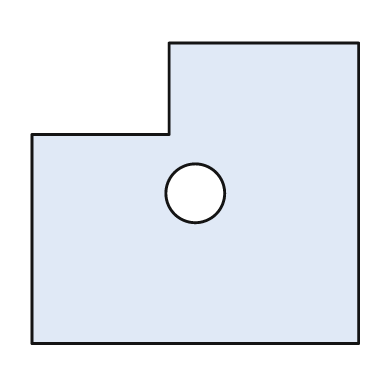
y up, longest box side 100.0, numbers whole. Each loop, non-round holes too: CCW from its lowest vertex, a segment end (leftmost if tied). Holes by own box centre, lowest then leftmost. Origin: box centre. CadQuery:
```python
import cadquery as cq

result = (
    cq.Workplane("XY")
    .moveTo(-50.0, -46.0)
    .lineTo(50.0, -46.0)
    .lineTo(50.0, 46.0)
    .lineTo(-8.0, 46.0)
    .lineTo(-8.0, 18.0)
    .lineTo(-50.0, 18.0)
    .close()
    .moveTo(0.0, 0.0)
    .circle(9.0)
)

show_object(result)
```